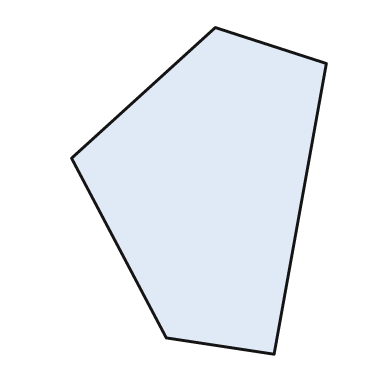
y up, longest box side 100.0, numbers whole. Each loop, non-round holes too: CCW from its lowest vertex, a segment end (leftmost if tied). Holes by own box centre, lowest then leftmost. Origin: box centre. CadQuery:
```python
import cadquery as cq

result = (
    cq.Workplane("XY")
    .moveTo(23.0, -50.0)
    .lineTo(39.0, 39.0)
    .lineTo(5.0, 50.0)
    .lineTo(-39.0, 10.0)
    .lineTo(-10.0, -45.0)
    .close()
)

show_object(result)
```